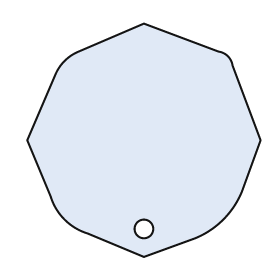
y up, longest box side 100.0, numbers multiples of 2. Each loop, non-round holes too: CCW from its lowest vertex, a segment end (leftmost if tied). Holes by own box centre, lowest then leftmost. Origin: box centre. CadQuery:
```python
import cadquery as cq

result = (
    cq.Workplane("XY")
    .moveTo(0.0, -50.0)
    .lineTo(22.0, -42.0)
    .threePointArc((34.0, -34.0), (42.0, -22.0))
    .lineTo(50.0, 0.0)
    .lineTo(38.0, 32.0)
    .threePointArc((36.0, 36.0), (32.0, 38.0))
    .lineTo(0.0, 50.0)
    .lineTo(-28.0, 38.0)
    .threePointArc((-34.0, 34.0), (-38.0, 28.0))
    .lineTo(-50.0, 0.0)
    .lineTo(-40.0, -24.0)
    .threePointArc((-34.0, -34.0), (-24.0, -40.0))
    .close()
    .moveTo(0.0, -38.0)
    .circle(4.0)
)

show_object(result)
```